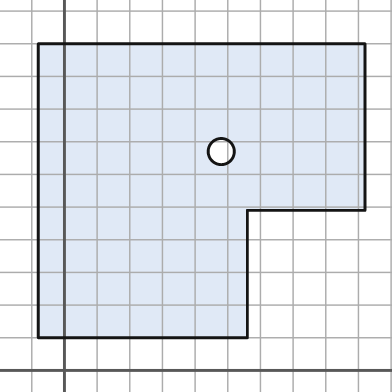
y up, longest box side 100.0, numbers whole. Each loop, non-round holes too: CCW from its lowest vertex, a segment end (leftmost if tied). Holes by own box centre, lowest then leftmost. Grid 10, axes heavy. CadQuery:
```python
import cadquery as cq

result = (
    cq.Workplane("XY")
    .moveTo(-8.0, 10.0)
    .lineTo(56.0, 10.0)
    .lineTo(56.0, 49.0)
    .lineTo(92.0, 49.0)
    .lineTo(92.0, 100.0)
    .lineTo(-8.0, 100.0)
    .close()
    .moveTo(48.0, 67.0)
    .circle(4.0)
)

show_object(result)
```